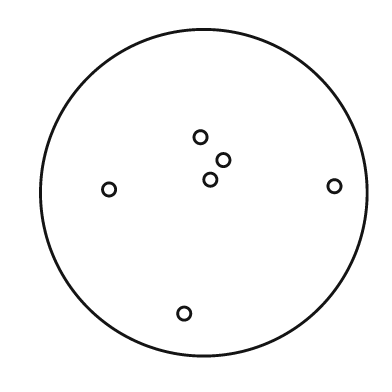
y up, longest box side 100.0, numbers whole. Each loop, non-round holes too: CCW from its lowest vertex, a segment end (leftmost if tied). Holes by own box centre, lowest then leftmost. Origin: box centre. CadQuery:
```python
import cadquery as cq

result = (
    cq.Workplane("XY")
    .moveTo(0.0, 0.0)
    .circle(50.0)
    .moveTo(-6.0, -37.0)
    .circle(2.0)
    .moveTo(-29.0, 1.0)
    .circle(2.0)
    .moveTo(40.0, 2.0)
    .circle(2.0)
    .moveTo(2.0, 4.0)
    .circle(2.0)
    .moveTo(6.0, 10.0)
    .circle(2.0)
    .moveTo(-1.0, 17.0)
    .circle(2.0)
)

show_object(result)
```